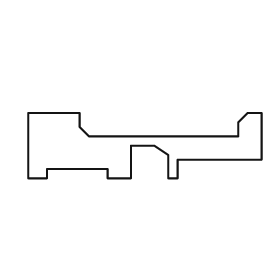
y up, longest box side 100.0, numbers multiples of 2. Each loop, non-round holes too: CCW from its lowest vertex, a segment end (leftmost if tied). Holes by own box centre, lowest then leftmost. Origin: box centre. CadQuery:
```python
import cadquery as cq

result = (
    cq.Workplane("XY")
    .moveTo(-50.0, -14.0)
    .lineTo(-42.0, -14.0)
    .lineTo(-42.0, -10.0)
    .lineTo(-16.0, -10.0)
    .lineTo(-16.0, -14.0)
    .lineTo(-6.0, -14.0)
    .lineTo(-6.0, 0.0)
    .lineTo(4.0, 0.0)
    .lineTo(10.0, -4.0)
    .lineTo(10.0, -14.0)
    .lineTo(14.0, -14.0)
    .lineTo(14.0, -6.0)
    .lineTo(50.0, -6.0)
    .lineTo(50.0, 14.0)
    .lineTo(44.0, 14.0)
    .lineTo(40.0, 10.0)
    .lineTo(40.0, 4.0)
    .lineTo(-24.0, 4.0)
    .lineTo(-28.0, 8.0)
    .lineTo(-28.0, 14.0)
    .lineTo(-50.0, 14.0)
    .close()
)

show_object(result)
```